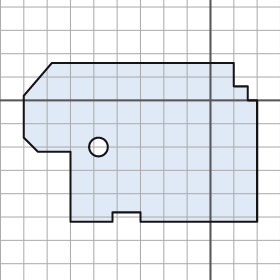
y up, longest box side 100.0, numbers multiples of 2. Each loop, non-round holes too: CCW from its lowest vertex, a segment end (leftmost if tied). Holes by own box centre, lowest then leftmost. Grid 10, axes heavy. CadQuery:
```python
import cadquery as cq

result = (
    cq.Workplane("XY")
    .moveTo(-60.0, -52.0)
    .lineTo(-42.0, -52.0)
    .lineTo(-42.0, -48.0)
    .lineTo(-30.0, -48.0)
    .lineTo(-30.0, -52.0)
    .lineTo(20.0, -52.0)
    .lineTo(20.0, 0.0)
    .lineTo(16.0, 0.0)
    .lineTo(16.0, 6.0)
    .lineTo(10.0, 6.0)
    .lineTo(10.0, 16.0)
    .lineTo(-68.0, 16.0)
    .lineTo(-80.0, 2.0)
    .lineTo(-80.0, -16.0)
    .lineTo(-74.0, -22.0)
    .lineTo(-60.0, -22.0)
    .close()
    .moveTo(-48.0, -20.0)
    .circle(4.0)
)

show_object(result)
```